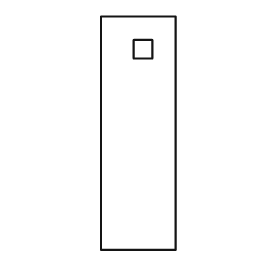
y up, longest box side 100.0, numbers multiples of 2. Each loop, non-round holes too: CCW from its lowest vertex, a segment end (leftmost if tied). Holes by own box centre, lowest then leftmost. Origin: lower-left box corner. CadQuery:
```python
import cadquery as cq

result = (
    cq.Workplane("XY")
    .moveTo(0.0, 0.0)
    .lineTo(32.0, 0.0)
    .lineTo(32.0, 100.0)
    .lineTo(0.0, 100.0)
    .close()
    .moveTo(14.0, 82.0)
    .lineTo(22.0, 82.0)
    .lineTo(22.0, 90.0)
    .lineTo(14.0, 90.0)
    .close()
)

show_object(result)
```